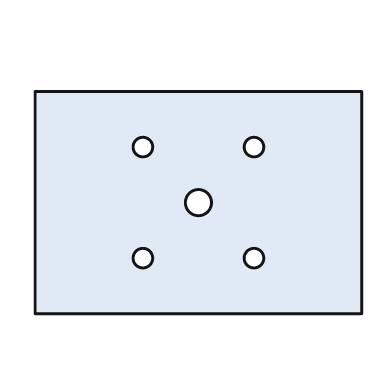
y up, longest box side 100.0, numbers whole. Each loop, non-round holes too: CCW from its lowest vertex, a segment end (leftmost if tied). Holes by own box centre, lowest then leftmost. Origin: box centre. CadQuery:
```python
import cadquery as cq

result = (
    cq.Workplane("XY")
    .moveTo(-50.0, -34.0)
    .lineTo(50.0, -34.0)
    .lineTo(50.0, 34.0)
    .lineTo(-50.0, 34.0)
    .close()
    .moveTo(-17.0, -17.0)
    .circle(3.0)
    .moveTo(17.0, -17.0)
    .circle(3.0)
    .moveTo(0.0, 0.0)
    .circle(4.0)
    .moveTo(-17.0, 17.0)
    .circle(3.0)
    .moveTo(17.0, 17.0)
    .circle(3.0)
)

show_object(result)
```